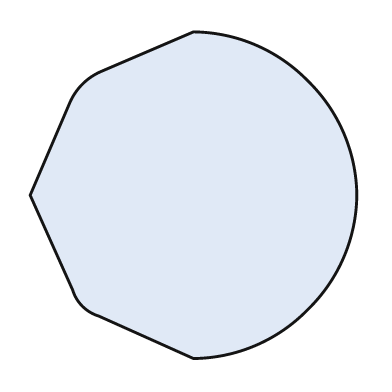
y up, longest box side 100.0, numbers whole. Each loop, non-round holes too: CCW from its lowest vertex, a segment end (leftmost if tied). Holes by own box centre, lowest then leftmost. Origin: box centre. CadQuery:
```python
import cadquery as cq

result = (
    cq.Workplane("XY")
    .moveTo(0.0, -50.0)
    .threePointArc((19.0, -46.0), (35.0, -35.0))
    .threePointArc((46.0, -19.0), (50.0, 0.0))
    .threePointArc((46.0, 19.0), (35.0, 35.0))
    .threePointArc((19.0, 46.0), (0.0, 50.0))
    .lineTo(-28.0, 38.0)
    .threePointArc((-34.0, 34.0), (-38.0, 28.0))
    .lineTo(-50.0, 0.0)
    .lineTo(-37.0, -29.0)
    .threePointArc((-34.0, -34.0), (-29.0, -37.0))
    .close()
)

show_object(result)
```